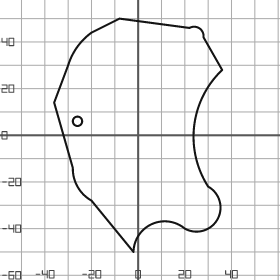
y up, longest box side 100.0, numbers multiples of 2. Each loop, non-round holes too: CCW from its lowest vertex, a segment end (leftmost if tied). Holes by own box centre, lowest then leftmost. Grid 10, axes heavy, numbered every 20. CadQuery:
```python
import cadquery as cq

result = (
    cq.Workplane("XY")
    .moveTo(-2.0, -50.0)
    .threePointArc((6.0, -38.0), (20.0, -40.0))
    .threePointArc((34.0, -36.0), (30.0, -22.0))
    .threePointArc((24.0, 4.0), (36.0, 28.0))
    .lineTo(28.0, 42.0)
    .threePointArc((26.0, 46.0), (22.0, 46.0))
    .lineTo(-8.0, 50.0)
    .lineTo(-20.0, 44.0)
    .threePointArc((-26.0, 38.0), (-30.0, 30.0))
    .lineTo(-36.0, 14.0)
    .lineTo(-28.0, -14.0)
    .threePointArc((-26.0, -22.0), (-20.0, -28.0))
    .close()
    .moveTo(-26.0, 6.0)
    .circle(2.0)
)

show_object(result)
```